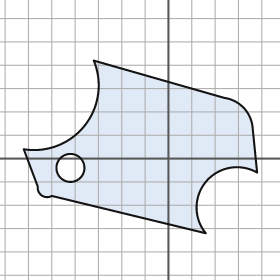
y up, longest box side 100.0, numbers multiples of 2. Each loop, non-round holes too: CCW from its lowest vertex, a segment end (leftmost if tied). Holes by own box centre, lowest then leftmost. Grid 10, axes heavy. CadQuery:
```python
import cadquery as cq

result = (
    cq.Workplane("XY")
    .moveTo(16.0, -32.0)
    .threePointArc((16.0, -10.0), (38.0, -6.0))
    .lineTo(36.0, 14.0)
    .threePointArc((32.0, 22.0), (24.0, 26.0))
    .lineTo(-32.0, 42.0)
    .threePointArc((-36.0, 14.0), (-62.0, 4.0))
    .lineTo(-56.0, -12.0)
    .threePointArc((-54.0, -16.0), (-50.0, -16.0))
    .close()
    .moveTo(-42.0, -4.0)
    .circle(6.0)
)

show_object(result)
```